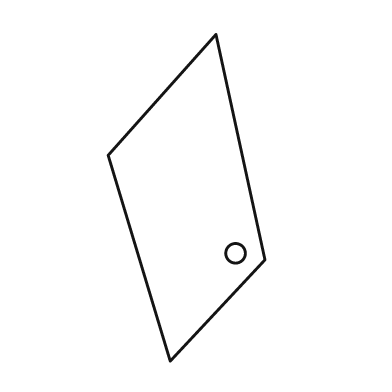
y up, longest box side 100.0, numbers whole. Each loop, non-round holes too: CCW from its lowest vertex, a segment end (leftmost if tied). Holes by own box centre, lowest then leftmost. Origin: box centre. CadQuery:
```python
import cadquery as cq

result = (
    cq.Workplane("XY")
    .moveTo(-5.0, -50.0)
    .lineTo(24.0, -19.0)
    .lineTo(9.0, 50.0)
    .lineTo(-24.0, 13.0)
    .close()
    .moveTo(15.0, -17.0)
    .circle(3.0)
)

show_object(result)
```